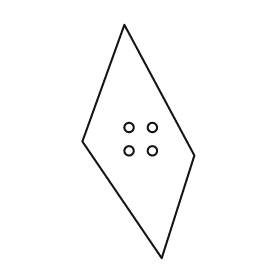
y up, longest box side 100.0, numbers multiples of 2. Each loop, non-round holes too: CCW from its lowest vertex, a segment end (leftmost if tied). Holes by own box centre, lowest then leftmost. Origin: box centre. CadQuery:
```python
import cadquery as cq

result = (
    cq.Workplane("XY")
    .moveTo(10.0, -50.0)
    .lineTo(24.0, -6.0)
    .lineTo(-6.0, 50.0)
    .lineTo(-24.0, 0.0)
    .close()
    .moveTo(-4.0, -4.0)
    .circle(2.0)
    .moveTo(6.0, -4.0)
    .circle(2.0)
    .moveTo(-4.0, 6.0)
    .circle(2.0)
    .moveTo(6.0, 6.0)
    .circle(2.0)
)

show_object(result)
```